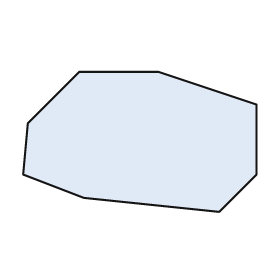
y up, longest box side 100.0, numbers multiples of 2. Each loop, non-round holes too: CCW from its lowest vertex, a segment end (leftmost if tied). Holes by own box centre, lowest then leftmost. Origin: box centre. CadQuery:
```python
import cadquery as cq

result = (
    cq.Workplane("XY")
    .moveTo(34.0, -30.0)
    .lineTo(50.0, -14.0)
    .lineTo(50.0, 16.0)
    .lineTo(8.0, 30.0)
    .lineTo(-26.0, 30.0)
    .lineTo(-48.0, 8.0)
    .lineTo(-50.0, -14.0)
    .lineTo(-24.0, -24.0)
    .close()
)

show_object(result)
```